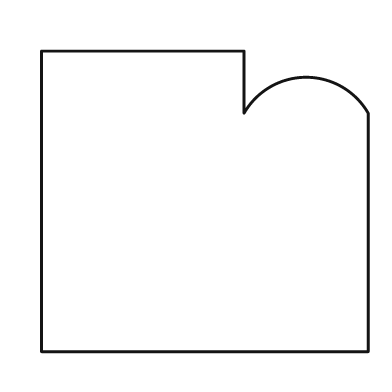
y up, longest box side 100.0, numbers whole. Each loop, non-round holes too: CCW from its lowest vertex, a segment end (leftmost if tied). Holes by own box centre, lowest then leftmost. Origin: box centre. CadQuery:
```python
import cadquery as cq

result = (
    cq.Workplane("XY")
    .moveTo(-50.0, -46.0)
    .lineTo(50.0, -46.0)
    .lineTo(50.0, 27.0)
    .threePointArc((31.0, 38.0), (12.0, 27.0))
    .lineTo(12.0, 46.0)
    .lineTo(-50.0, 46.0)
    .close()
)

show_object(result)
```